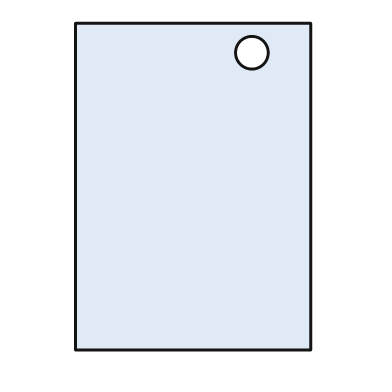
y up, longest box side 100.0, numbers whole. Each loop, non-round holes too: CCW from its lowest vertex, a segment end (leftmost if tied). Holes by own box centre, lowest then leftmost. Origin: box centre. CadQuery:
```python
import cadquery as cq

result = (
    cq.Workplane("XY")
    .moveTo(-36.0, -50.0)
    .lineTo(36.0, -50.0)
    .lineTo(36.0, 50.0)
    .lineTo(-36.0, 50.0)
    .close()
    .moveTo(18.0, 41.0)
    .circle(5.0)
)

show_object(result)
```